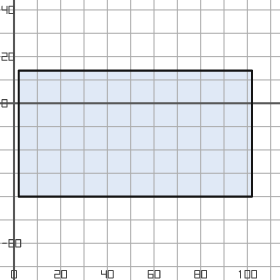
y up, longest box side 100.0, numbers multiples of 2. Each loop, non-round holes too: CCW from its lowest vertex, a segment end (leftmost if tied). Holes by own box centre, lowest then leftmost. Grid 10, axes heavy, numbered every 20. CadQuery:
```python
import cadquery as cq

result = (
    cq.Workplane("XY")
    .moveTo(2.0, -40.0)
    .lineTo(102.0, -40.0)
    .lineTo(102.0, 14.0)
    .lineTo(2.0, 14.0)
    .close()
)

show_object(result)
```